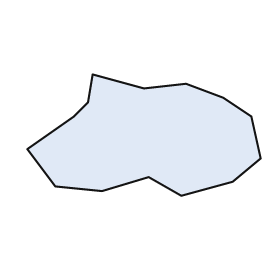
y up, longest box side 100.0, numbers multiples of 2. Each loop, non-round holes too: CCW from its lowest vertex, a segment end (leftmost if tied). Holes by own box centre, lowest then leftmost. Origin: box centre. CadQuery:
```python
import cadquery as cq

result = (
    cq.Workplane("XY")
    .moveTo(16.0, -26.0)
    .lineTo(38.0, -20.0)
    .lineTo(50.0, -10.0)
    .lineTo(46.0, 8.0)
    .lineTo(34.0, 16.0)
    .lineTo(18.0, 22.0)
    .lineTo(0.0, 20.0)
    .lineTo(-22.0, 26.0)
    .lineTo(-24.0, 14.0)
    .lineTo(-30.0, 8.0)
    .lineTo(-50.0, -6.0)
    .lineTo(-38.0, -22.0)
    .lineTo(-18.0, -24.0)
    .lineTo(2.0, -18.0)
    .close()
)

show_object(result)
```